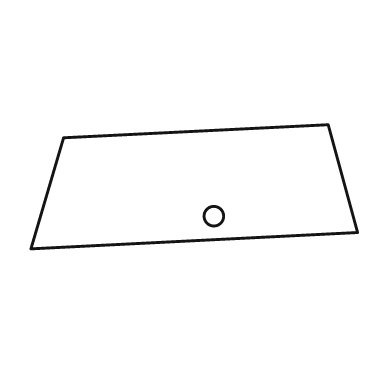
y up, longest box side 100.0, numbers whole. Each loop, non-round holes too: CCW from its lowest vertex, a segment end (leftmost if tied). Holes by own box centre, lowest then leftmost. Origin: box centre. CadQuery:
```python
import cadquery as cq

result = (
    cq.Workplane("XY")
    .moveTo(-50.0, -19.0)
    .lineTo(50.0, -14.0)
    .lineTo(41.0, 19.0)
    .lineTo(-40.0, 15.0)
    .close()
    .moveTo(6.0, -9.0)
    .circle(3.0)
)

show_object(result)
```